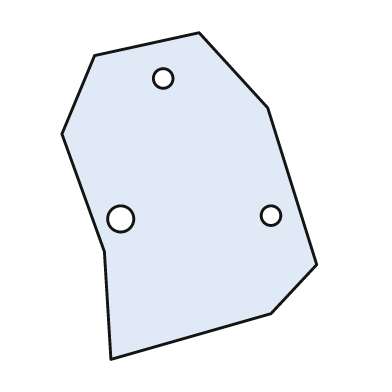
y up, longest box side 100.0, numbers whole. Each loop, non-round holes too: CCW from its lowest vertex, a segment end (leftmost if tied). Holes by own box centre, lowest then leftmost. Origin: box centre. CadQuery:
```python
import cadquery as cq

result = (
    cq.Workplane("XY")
    .moveTo(-24.0, -50.0)
    .lineTo(25.0, -36.0)
    .lineTo(39.0, -21.0)
    .lineTo(24.0, 27.0)
    .lineTo(3.0, 50.0)
    .lineTo(-29.0, 43.0)
    .lineTo(-39.0, 19.0)
    .lineTo(-26.0, -17.0)
    .close()
    .moveTo(-21.0, -7.0)
    .circle(4.0)
    .moveTo(25.0, -6.0)
    .circle(3.0)
    .moveTo(-8.0, 36.0)
    .circle(3.0)
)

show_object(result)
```